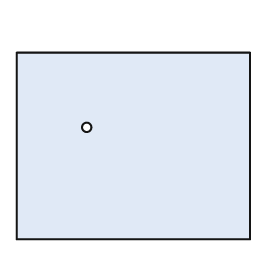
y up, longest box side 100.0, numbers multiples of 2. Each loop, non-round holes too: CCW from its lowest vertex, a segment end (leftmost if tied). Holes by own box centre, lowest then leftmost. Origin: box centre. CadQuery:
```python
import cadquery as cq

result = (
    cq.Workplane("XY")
    .moveTo(-50.0, -40.0)
    .lineTo(50.0, -40.0)
    .lineTo(50.0, 40.0)
    .lineTo(-50.0, 40.0)
    .close()
    .moveTo(-20.0, 8.0)
    .circle(2.0)
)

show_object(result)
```